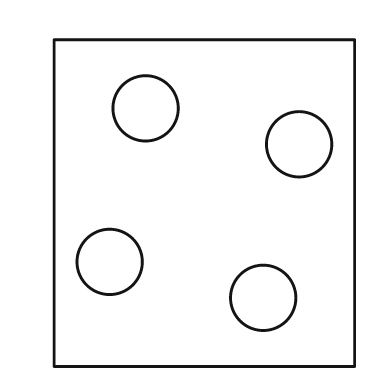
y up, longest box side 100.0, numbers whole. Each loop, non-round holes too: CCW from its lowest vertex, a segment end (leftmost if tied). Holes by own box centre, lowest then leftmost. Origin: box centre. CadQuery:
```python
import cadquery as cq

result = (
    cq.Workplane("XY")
    .moveTo(-46.0, -50.0)
    .lineTo(46.0, -50.0)
    .lineTo(46.0, 50.0)
    .lineTo(-46.0, 50.0)
    .close()
    .moveTo(18.0, -29.0)
    .circle(10.0)
    .moveTo(-29.0, -18.0)
    .circle(10.0)
    .moveTo(29.0, 18.0)
    .circle(10.0)
    .moveTo(-18.0, 29.0)
    .circle(10.0)
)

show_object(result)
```